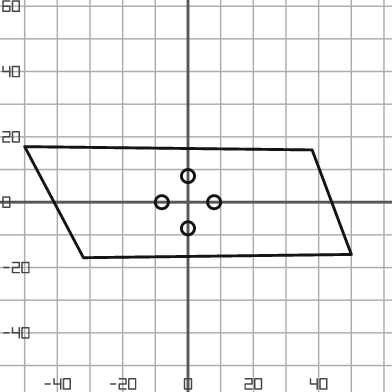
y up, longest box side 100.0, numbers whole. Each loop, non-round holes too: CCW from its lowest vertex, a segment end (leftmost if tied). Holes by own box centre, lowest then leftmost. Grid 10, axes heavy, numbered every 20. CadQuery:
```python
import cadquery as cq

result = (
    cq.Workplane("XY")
    .moveTo(-32.0, -17.0)
    .lineTo(50.0, -16.0)
    .lineTo(38.0, 16.0)
    .lineTo(-50.0, 17.0)
    .close()
    .moveTo(0.0, -8.0)
    .circle(2.0)
    .moveTo(-8.0, 0.0)
    .circle(2.0)
    .moveTo(8.0, 0.0)
    .circle(2.0)
    .moveTo(0.0, 8.0)
    .circle(2.0)
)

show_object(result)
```